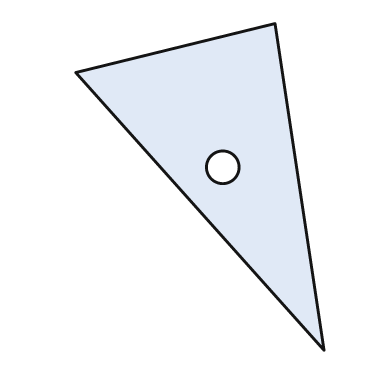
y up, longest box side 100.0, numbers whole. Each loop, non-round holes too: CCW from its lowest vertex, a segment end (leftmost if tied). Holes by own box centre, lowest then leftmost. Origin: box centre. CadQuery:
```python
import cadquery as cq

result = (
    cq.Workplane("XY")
    .moveTo(38.0, -50.0)
    .lineTo(23.0, 50.0)
    .lineTo(-38.0, 35.0)
    .close()
    .moveTo(7.0, 6.0)
    .circle(5.0)
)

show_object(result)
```